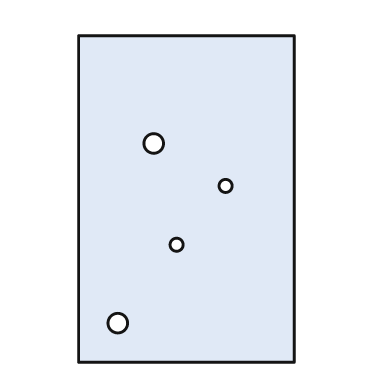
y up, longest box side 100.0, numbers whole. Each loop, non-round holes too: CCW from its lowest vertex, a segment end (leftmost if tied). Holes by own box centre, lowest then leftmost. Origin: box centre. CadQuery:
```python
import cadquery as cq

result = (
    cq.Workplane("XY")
    .moveTo(-33.0, -50.0)
    .lineTo(33.0, -50.0)
    .lineTo(33.0, 50.0)
    .lineTo(-33.0, 50.0)
    .close()
    .moveTo(-21.0, -38.0)
    .circle(3.0)
    .moveTo(-3.0, -14.0)
    .circle(2.0)
    .moveTo(12.0, 4.0)
    .circle(2.0)
    .moveTo(-10.0, 17.0)
    .circle(3.0)
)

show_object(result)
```